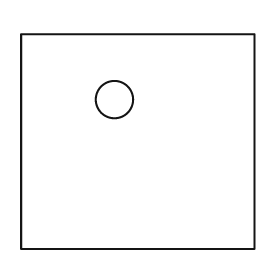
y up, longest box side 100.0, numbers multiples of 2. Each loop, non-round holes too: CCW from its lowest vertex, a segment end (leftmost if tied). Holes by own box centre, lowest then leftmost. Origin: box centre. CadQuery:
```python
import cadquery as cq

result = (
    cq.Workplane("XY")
    .moveTo(-50.0, -46.0)
    .lineTo(50.0, -46.0)
    .lineTo(50.0, 46.0)
    .lineTo(-50.0, 46.0)
    .close()
    .moveTo(-10.0, 18.0)
    .circle(8.0)
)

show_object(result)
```